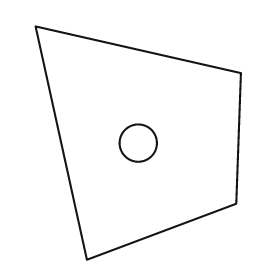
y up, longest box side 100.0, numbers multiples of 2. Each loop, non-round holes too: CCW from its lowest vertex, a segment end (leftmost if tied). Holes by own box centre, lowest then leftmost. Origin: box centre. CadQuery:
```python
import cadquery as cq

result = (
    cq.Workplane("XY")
    .moveTo(-22.0, -50.0)
    .lineTo(42.0, -26.0)
    .lineTo(44.0, 30.0)
    .lineTo(-44.0, 50.0)
    .close()
    .moveTo(0.0, 0.0)
    .circle(8.0)
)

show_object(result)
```